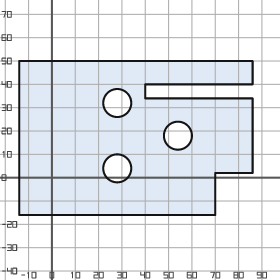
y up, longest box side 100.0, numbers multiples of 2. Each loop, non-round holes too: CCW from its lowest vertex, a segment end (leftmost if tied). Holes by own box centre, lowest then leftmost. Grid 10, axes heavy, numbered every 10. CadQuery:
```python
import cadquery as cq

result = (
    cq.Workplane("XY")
    .moveTo(-14.0, -16.0)
    .lineTo(70.0, -16.0)
    .lineTo(70.0, 2.0)
    .lineTo(86.0, 2.0)
    .lineTo(86.0, 34.0)
    .lineTo(40.0, 34.0)
    .lineTo(40.0, 40.0)
    .lineTo(86.0, 40.0)
    .lineTo(86.0, 50.0)
    .lineTo(-14.0, 50.0)
    .close()
    .moveTo(28.0, 4.0)
    .circle(6.0)
    .moveTo(54.0, 18.0)
    .circle(6.0)
    .moveTo(28.0, 32.0)
    .circle(6.0)
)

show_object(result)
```